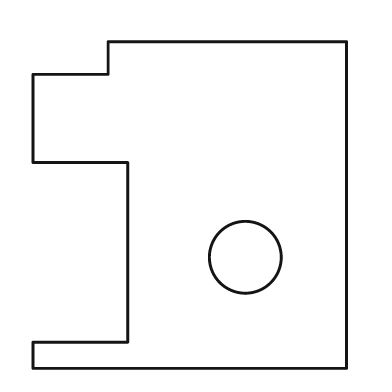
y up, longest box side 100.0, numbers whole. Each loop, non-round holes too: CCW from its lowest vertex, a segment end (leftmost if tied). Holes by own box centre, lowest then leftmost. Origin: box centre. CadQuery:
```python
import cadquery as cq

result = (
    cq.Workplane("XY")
    .moveTo(-48.0, -50.0)
    .lineTo(48.0, -50.0)
    .lineTo(48.0, 50.0)
    .lineTo(-25.0, 50.0)
    .lineTo(-25.0, 40.0)
    .lineTo(-48.0, 40.0)
    .lineTo(-48.0, 13.0)
    .lineTo(-19.0, 13.0)
    .lineTo(-19.0, -42.0)
    .lineTo(-48.0, -42.0)
    .close()
    .moveTo(17.0, -16.0)
    .circle(11.0)
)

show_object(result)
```